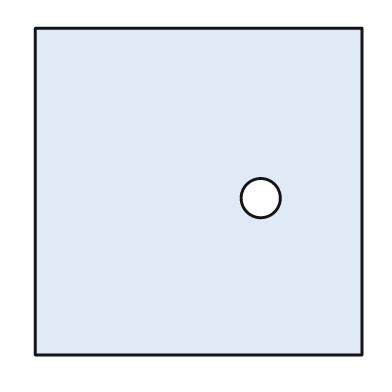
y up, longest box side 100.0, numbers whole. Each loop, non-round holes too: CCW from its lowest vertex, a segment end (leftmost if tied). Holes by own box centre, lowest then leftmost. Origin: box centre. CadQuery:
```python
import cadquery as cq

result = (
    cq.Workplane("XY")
    .moveTo(-50.0, -50.0)
    .lineTo(50.0, -50.0)
    .lineTo(50.0, 50.0)
    .lineTo(-50.0, 50.0)
    .close()
    .moveTo(19.0, -2.0)
    .circle(6.0)
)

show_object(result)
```